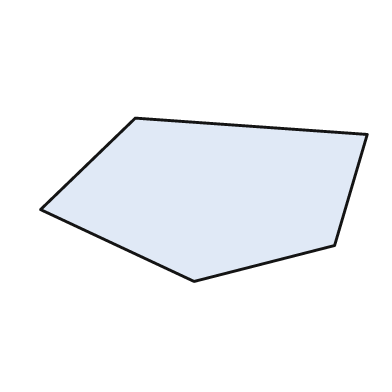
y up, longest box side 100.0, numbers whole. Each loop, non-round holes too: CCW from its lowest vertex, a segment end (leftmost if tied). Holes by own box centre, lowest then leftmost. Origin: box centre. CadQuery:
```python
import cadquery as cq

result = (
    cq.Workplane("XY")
    .moveTo(-3.0, -25.0)
    .lineTo(40.0, -14.0)
    .lineTo(50.0, 20.0)
    .lineTo(-21.0, 25.0)
    .lineTo(-50.0, -3.0)
    .close()
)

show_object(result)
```